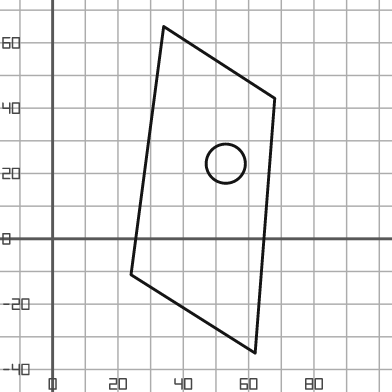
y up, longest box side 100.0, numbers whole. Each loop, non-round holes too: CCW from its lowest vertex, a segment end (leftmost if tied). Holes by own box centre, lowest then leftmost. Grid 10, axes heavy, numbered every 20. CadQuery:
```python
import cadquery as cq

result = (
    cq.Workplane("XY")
    .moveTo(62.0, -35.0)
    .lineTo(68.0, 43.0)
    .lineTo(34.0, 65.0)
    .lineTo(24.0, -11.0)
    .close()
    .moveTo(53.0, 23.0)
    .circle(6.0)
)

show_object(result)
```